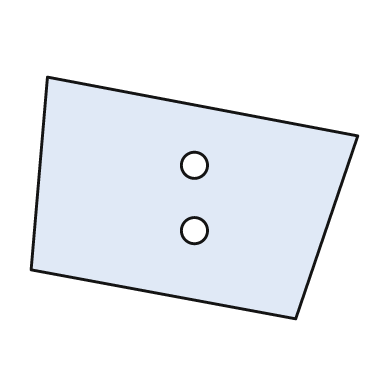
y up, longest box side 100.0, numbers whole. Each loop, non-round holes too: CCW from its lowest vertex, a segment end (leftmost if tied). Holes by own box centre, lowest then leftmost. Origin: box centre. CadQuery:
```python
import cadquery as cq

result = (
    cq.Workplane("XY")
    .moveTo(31.0, -37.0)
    .lineTo(50.0, 19.0)
    .lineTo(-45.0, 37.0)
    .lineTo(-50.0, -22.0)
    .close()
    .moveTo(0.0, -10.0)
    .circle(4.0)
    .moveTo(0.0, 10.0)
    .circle(4.0)
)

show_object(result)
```